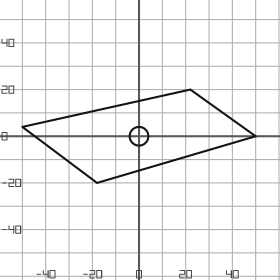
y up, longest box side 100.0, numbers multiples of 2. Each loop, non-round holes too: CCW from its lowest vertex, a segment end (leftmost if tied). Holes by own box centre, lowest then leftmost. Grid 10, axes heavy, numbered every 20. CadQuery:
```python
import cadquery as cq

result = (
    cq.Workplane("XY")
    .moveTo(-18.0, -20.0)
    .lineTo(50.0, 0.0)
    .lineTo(22.0, 20.0)
    .lineTo(-50.0, 4.0)
    .close()
    .moveTo(0.0, 0.0)
    .circle(4.0)
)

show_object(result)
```